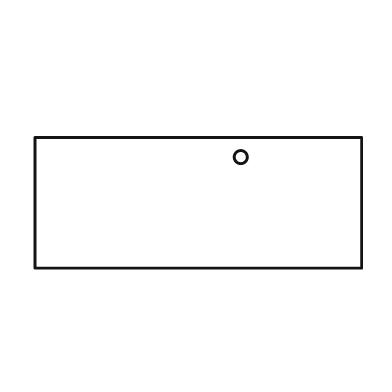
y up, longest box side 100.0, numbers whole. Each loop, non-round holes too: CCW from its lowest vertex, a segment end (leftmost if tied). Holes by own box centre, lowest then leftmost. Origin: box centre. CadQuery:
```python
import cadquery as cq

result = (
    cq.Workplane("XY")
    .moveTo(-50.0, -20.0)
    .lineTo(50.0, -20.0)
    .lineTo(50.0, 20.0)
    .lineTo(-50.0, 20.0)
    .close()
    .moveTo(13.0, 14.0)
    .circle(2.0)
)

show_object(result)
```